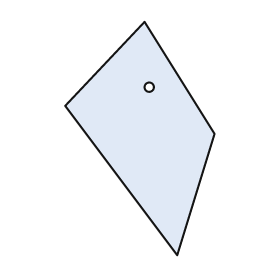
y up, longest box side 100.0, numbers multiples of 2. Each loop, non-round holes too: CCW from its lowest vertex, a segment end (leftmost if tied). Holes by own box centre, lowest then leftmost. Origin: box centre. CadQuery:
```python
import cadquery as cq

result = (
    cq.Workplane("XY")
    .moveTo(16.0, -50.0)
    .lineTo(32.0, 2.0)
    .lineTo(2.0, 50.0)
    .lineTo(-32.0, 14.0)
    .close()
    .moveTo(4.0, 22.0)
    .circle(2.0)
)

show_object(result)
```